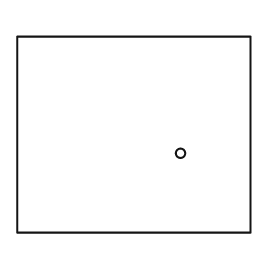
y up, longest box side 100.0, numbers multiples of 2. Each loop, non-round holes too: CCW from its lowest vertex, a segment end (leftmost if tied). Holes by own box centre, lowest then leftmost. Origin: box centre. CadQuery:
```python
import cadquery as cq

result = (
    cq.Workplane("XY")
    .moveTo(-50.0, -42.0)
    .lineTo(50.0, -42.0)
    .lineTo(50.0, 42.0)
    .lineTo(-50.0, 42.0)
    .close()
    .moveTo(20.0, -8.0)
    .circle(2.0)
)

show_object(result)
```